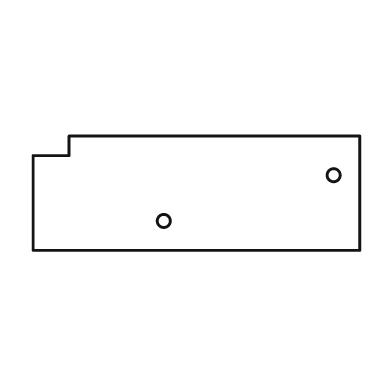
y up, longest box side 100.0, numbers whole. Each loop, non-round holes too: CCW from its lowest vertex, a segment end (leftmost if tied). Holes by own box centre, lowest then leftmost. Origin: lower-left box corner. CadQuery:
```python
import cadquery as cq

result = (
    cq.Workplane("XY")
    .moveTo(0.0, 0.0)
    .lineTo(100.0, 0.0)
    .lineTo(100.0, 35.0)
    .lineTo(11.0, 35.0)
    .lineTo(11.0, 29.0)
    .lineTo(0.0, 29.0)
    .close()
    .moveTo(40.0, 9.0)
    .circle(2.0)
    .moveTo(92.0, 23.0)
    .circle(2.0)
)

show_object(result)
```